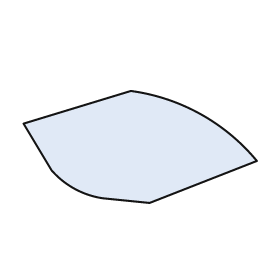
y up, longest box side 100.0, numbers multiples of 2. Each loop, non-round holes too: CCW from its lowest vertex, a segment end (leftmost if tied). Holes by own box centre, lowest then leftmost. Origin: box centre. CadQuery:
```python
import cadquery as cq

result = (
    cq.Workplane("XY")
    .moveTo(4.0, -24.0)
    .lineTo(50.0, -6.0)
    .threePointArc((26.0, 14.0), (-4.0, 24.0))
    .lineTo(-50.0, 10.0)
    .lineTo(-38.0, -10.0)
    .threePointArc((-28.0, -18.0), (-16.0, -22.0))
    .close()
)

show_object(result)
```